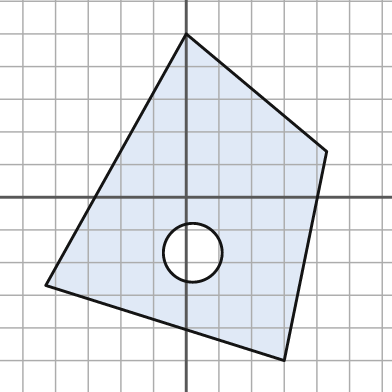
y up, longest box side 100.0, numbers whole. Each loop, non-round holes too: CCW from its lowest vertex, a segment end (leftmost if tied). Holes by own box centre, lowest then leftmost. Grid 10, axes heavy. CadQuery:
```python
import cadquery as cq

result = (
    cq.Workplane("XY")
    .moveTo(30.0, -50.0)
    .lineTo(43.0, 14.0)
    .lineTo(0.0, 50.0)
    .lineTo(-43.0, -27.0)
    .close()
    .moveTo(2.0, -17.0)
    .circle(9.0)
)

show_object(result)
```